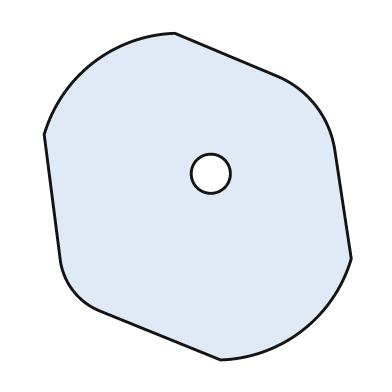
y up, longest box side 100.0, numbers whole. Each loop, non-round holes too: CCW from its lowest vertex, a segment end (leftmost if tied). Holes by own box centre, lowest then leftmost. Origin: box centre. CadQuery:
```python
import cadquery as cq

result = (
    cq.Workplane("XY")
    .moveTo(7.0, -50.0)
    .threePointArc((32.0, -41.0), (47.0, -19.0))
    .lineTo(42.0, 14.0)
    .threePointArc((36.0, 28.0), (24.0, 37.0))
    .lineTo(-7.0, 50.0)
    .threePointArc((-32.0, 41.0), (-47.0, 19.0))
    .lineTo(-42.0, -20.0)
    .threePointArc((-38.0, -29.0), (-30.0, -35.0))
    .close()
    .moveTo(4.0, 7.0)
    .circle(6.0)
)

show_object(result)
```